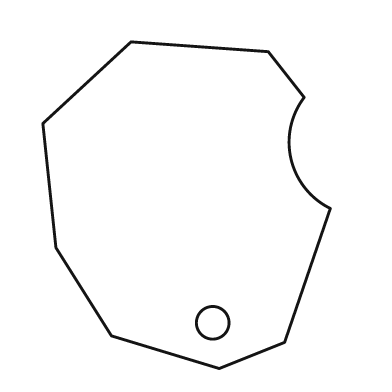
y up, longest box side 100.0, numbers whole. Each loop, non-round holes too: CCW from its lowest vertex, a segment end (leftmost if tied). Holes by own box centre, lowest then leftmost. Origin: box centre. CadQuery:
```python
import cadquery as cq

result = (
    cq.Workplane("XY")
    .moveTo(10.0, -50.0)
    .lineTo(30.0, -42.0)
    .lineTo(44.0, -1.0)
    .threePointArc((32.0, 14.0), (36.0, 33.0))
    .lineTo(25.0, 47.0)
    .lineTo(-17.0, 50.0)
    .lineTo(-44.0, 25.0)
    .lineTo(-40.0, -13.0)
    .lineTo(-23.0, -40.0)
    .close()
    .moveTo(8.0, -36.0)
    .circle(5.0)
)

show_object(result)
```